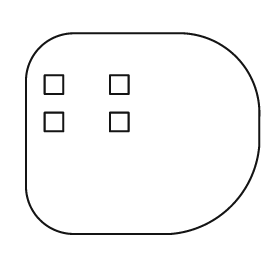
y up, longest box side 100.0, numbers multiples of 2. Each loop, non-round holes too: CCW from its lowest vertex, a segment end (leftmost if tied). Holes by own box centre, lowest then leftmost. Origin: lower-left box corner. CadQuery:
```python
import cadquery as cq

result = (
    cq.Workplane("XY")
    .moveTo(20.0, 0.0)
    .lineTo(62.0, 0.0)
    .threePointArc((88.0, 12.0), (100.0, 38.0))
    .lineTo(100.0, 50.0)
    .threePointArc((90.0, 76.0), (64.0, 86.0))
    .lineTo(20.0, 86.0)
    .threePointArc((6.0, 80.0), (0.0, 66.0))
    .lineTo(0.0, 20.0)
    .threePointArc((6.0, 6.0), (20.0, 0.0))
    .close()
    .moveTo(8.0, 44.0)
    .lineTo(16.0, 44.0)
    .lineTo(16.0, 52.0)
    .lineTo(8.0, 52.0)
    .close()
    .moveTo(36.0, 44.0)
    .lineTo(44.0, 44.0)
    .lineTo(44.0, 52.0)
    .lineTo(36.0, 52.0)
    .close()
    .moveTo(8.0, 60.0)
    .lineTo(16.0, 60.0)
    .lineTo(16.0, 68.0)
    .lineTo(8.0, 68.0)
    .close()
    .moveTo(36.0, 60.0)
    .lineTo(44.0, 60.0)
    .lineTo(44.0, 68.0)
    .lineTo(36.0, 68.0)
    .close()
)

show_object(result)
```